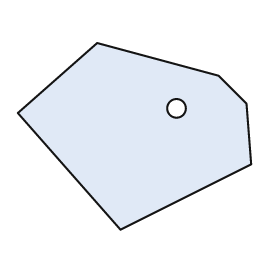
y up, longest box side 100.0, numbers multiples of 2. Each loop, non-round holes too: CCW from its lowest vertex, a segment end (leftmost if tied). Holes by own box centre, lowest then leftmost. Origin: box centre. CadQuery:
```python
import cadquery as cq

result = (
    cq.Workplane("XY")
    .moveTo(-6.0, -40.0)
    .lineTo(50.0, -12.0)
    .lineTo(48.0, 14.0)
    .lineTo(36.0, 26.0)
    .lineTo(-16.0, 40.0)
    .lineTo(-50.0, 10.0)
    .close()
    .moveTo(18.0, 12.0)
    .circle(4.0)
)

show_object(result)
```